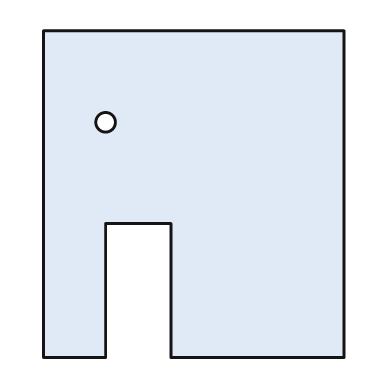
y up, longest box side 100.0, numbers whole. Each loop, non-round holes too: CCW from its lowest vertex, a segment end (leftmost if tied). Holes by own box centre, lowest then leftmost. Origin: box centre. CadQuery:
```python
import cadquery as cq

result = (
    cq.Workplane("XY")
    .moveTo(-46.0, -50.0)
    .lineTo(-27.0, -50.0)
    .lineTo(-27.0, -9.0)
    .lineTo(-7.0, -9.0)
    .lineTo(-7.0, -50.0)
    .lineTo(46.0, -50.0)
    .lineTo(46.0, 50.0)
    .lineTo(-46.0, 50.0)
    .close()
    .moveTo(-27.0, 22.0)
    .circle(3.0)
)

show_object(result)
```